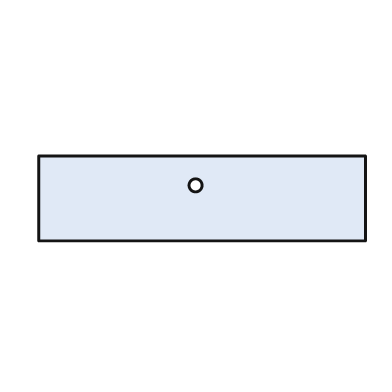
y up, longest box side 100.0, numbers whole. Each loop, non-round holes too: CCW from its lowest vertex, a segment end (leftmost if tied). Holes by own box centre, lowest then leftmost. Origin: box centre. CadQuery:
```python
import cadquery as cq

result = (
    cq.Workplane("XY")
    .moveTo(-50.0, -13.0)
    .lineTo(50.0, -13.0)
    .lineTo(50.0, 13.0)
    .lineTo(-50.0, 13.0)
    .close()
    .moveTo(-2.0, 4.0)
    .circle(2.0)
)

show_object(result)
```